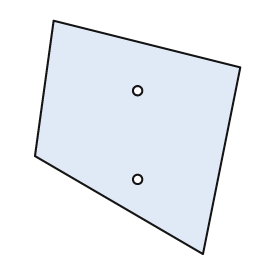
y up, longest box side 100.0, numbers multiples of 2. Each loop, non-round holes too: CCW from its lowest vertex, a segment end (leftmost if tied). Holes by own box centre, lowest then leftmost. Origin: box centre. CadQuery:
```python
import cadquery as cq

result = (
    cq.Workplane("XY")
    .moveTo(28.0, -50.0)
    .lineTo(44.0, 30.0)
    .lineTo(-36.0, 50.0)
    .lineTo(-44.0, -8.0)
    .close()
    .moveTo(0.0, -18.0)
    .circle(2.0)
    .moveTo(0.0, 20.0)
    .circle(2.0)
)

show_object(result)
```